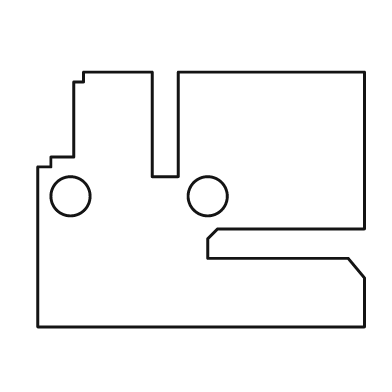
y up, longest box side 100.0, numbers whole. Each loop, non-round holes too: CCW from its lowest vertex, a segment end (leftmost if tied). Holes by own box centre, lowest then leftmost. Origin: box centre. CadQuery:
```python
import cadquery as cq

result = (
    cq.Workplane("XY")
    .moveTo(-50.0, -39.0)
    .lineTo(50.0, -39.0)
    .lineTo(50.0, -24.0)
    .lineTo(45.0, -18.0)
    .lineTo(2.0, -18.0)
    .lineTo(2.0, -12.0)
    .lineTo(5.0, -9.0)
    .lineTo(50.0, -9.0)
    .lineTo(50.0, 39.0)
    .lineTo(-7.0, 39.0)
    .lineTo(-7.0, 7.0)
    .lineTo(-15.0, 7.0)
    .lineTo(-15.0, 39.0)
    .lineTo(-36.0, 39.0)
    .lineTo(-36.0, 36.0)
    .lineTo(-39.0, 36.0)
    .lineTo(-39.0, 13.0)
    .lineTo(-46.0, 13.0)
    .lineTo(-46.0, 10.0)
    .lineTo(-50.0, 10.0)
    .close()
    .moveTo(-40.0, 1.0)
    .circle(6.0)
    .moveTo(2.0, 1.0)
    .circle(6.0)
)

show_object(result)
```